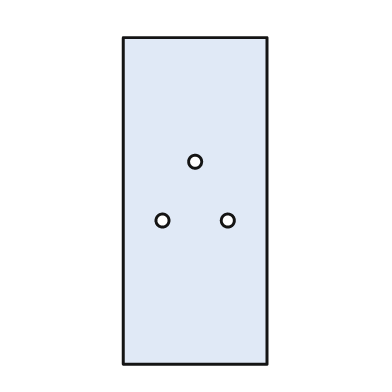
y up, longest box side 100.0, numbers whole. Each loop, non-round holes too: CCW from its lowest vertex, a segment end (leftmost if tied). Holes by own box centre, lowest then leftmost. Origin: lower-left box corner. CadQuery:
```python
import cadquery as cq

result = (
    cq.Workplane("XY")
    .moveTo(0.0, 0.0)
    .lineTo(44.0, 0.0)
    .lineTo(44.0, 100.0)
    .lineTo(0.0, 100.0)
    .close()
    .moveTo(12.0, 44.0)
    .circle(2.0)
    .moveTo(32.0, 44.0)
    .circle(2.0)
    .moveTo(22.0, 62.0)
    .circle(2.0)
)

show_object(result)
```